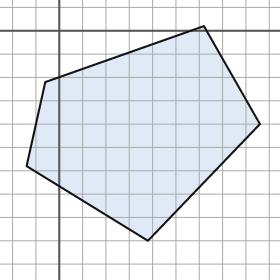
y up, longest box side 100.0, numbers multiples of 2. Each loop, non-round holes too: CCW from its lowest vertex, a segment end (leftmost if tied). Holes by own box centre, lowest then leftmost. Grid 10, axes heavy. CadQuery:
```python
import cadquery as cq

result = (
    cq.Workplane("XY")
    .moveTo(38.0, -90.0)
    .lineTo(86.0, -40.0)
    .lineTo(62.0, 2.0)
    .lineTo(-6.0, -22.0)
    .lineTo(-14.0, -58.0)
    .close()
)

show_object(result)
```